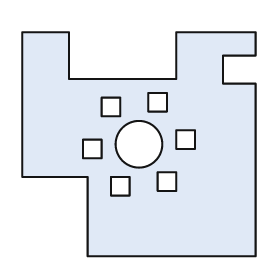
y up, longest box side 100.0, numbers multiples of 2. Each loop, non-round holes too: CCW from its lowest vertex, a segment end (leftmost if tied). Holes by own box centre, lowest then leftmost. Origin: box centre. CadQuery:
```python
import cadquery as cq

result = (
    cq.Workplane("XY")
    .moveTo(-22.0, -48.0)
    .lineTo(50.0, -48.0)
    .lineTo(50.0, 26.0)
    .lineTo(36.0, 26.0)
    .lineTo(36.0, 38.0)
    .lineTo(50.0, 38.0)
    .lineTo(50.0, 48.0)
    .lineTo(16.0, 48.0)
    .lineTo(16.0, 28.0)
    .lineTo(-30.0, 28.0)
    .lineTo(-30.0, 48.0)
    .lineTo(-50.0, 48.0)
    .lineTo(-50.0, -14.0)
    .lineTo(-22.0, -14.0)
    .close()
    .moveTo(-12.0, -22.0)
    .lineTo(-4.0, -22.0)
    .lineTo(-4.0, -14.0)
    .lineTo(-12.0, -14.0)
    .close()
    .moveTo(8.0, -20.0)
    .lineTo(16.0, -20.0)
    .lineTo(16.0, -12.0)
    .lineTo(8.0, -12.0)
    .close()
    .moveTo(-24.0, -6.0)
    .lineTo(-16.0, -6.0)
    .lineTo(-16.0, 2.0)
    .lineTo(-24.0, 2.0)
    .close()
    .moveTo(0.0, 0.0)
    .circle(10.0)
    .moveTo(16.0, -2.0)
    .lineTo(24.0, -2.0)
    .lineTo(24.0, 6.0)
    .lineTo(16.0, 6.0)
    .close()
    .moveTo(-16.0, 12.0)
    .lineTo(-8.0, 12.0)
    .lineTo(-8.0, 20.0)
    .lineTo(-16.0, 20.0)
    .close()
    .moveTo(4.0, 14.0)
    .lineTo(12.0, 14.0)
    .lineTo(12.0, 22.0)
    .lineTo(4.0, 22.0)
    .close()
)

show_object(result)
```